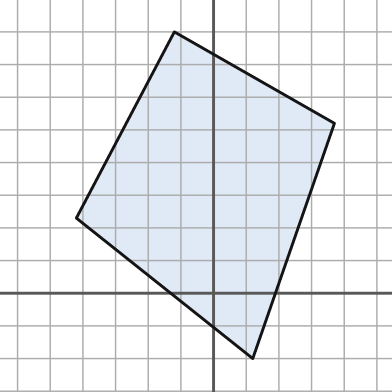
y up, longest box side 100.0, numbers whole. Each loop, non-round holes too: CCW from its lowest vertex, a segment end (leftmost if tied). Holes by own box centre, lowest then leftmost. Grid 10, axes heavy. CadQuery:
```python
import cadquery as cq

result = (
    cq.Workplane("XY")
    .moveTo(12.0, -20.0)
    .lineTo(37.0, 52.0)
    .lineTo(-12.0, 80.0)
    .lineTo(-42.0, 23.0)
    .close()
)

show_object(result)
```